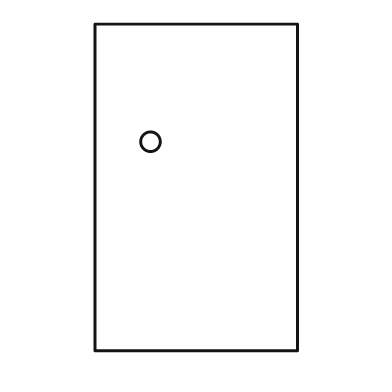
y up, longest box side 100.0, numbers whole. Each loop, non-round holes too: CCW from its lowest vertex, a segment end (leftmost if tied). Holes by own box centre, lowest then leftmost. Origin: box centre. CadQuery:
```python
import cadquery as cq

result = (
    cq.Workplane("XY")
    .moveTo(-31.0, -50.0)
    .lineTo(31.0, -50.0)
    .lineTo(31.0, 50.0)
    .lineTo(-31.0, 50.0)
    .close()
    .moveTo(-14.0, 14.0)
    .circle(3.0)
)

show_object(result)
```